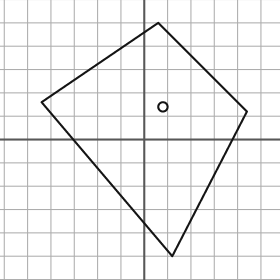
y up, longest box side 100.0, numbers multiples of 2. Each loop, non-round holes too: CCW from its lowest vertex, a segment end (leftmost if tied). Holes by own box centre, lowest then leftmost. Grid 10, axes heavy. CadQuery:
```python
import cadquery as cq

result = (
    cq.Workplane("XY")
    .moveTo(12.0, -50.0)
    .lineTo(44.0, 12.0)
    .lineTo(6.0, 50.0)
    .lineTo(-44.0, 16.0)
    .close()
    .moveTo(8.0, 14.0)
    .circle(2.0)
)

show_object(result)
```